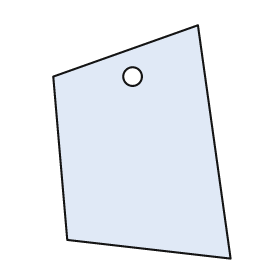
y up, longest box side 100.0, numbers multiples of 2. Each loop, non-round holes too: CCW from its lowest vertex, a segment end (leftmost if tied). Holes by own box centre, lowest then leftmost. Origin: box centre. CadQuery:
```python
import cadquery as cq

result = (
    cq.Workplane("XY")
    .moveTo(38.0, -50.0)
    .lineTo(24.0, 50.0)
    .lineTo(-38.0, 28.0)
    .lineTo(-32.0, -42.0)
    .close()
    .moveTo(-4.0, 28.0)
    .circle(4.0)
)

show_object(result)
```